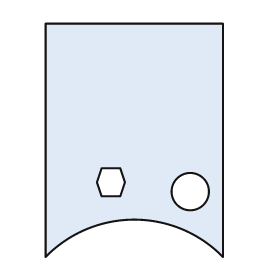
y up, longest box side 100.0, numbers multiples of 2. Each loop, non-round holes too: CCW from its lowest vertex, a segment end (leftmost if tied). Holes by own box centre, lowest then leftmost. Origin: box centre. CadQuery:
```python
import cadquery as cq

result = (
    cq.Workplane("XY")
    .moveTo(-38.0, -50.0)
    .threePointArc((0.0, -34.0), (38.0, -50.0))
    .lineTo(38.0, 50.0)
    .lineTo(-38.0, 50.0)
    .close()
    .moveTo(24.0, -22.0)
    .circle(8.0)
    .moveTo(-14.0, -24.0)
    .lineTo(-6.0, -24.0)
    .lineTo(-4.0, -18.0)
    .lineTo(-6.0, -12.0)
    .lineTo(-14.0, -12.0)
    .lineTo(-16.0, -18.0)
    .close()
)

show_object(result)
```